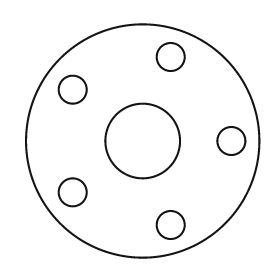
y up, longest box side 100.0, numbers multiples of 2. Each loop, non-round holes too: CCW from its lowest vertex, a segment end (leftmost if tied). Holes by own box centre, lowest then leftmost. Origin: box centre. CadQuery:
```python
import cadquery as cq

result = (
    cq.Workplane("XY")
    .moveTo(0.0, 0.0)
    .circle(50.0)
    .moveTo(12.0, -36.0)
    .circle(6.0)
    .moveTo(-30.0, -22.0)
    .circle(6.0)
    .moveTo(0.0, 0.0)
    .circle(16.0)
    .moveTo(38.0, 0.0)
    .circle(6.0)
    .moveTo(-30.0, 22.0)
    .circle(6.0)
    .moveTo(12.0, 36.0)
    .circle(6.0)
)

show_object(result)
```